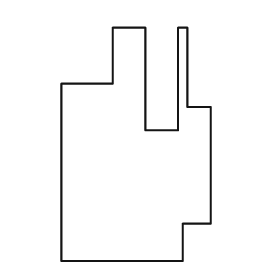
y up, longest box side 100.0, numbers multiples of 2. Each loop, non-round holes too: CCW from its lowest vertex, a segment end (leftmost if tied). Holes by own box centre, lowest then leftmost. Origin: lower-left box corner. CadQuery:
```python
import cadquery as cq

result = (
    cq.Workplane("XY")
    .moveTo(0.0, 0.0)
    .lineTo(52.0, 0.0)
    .lineTo(52.0, 16.0)
    .lineTo(64.0, 16.0)
    .lineTo(64.0, 66.0)
    .lineTo(54.0, 66.0)
    .lineTo(54.0, 100.0)
    .lineTo(50.0, 100.0)
    .lineTo(50.0, 56.0)
    .lineTo(36.0, 56.0)
    .lineTo(36.0, 100.0)
    .lineTo(22.0, 100.0)
    .lineTo(22.0, 76.0)
    .lineTo(0.0, 76.0)
    .close()
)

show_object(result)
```